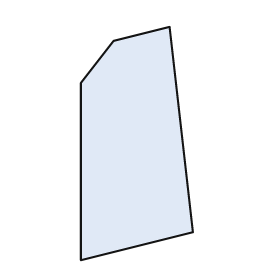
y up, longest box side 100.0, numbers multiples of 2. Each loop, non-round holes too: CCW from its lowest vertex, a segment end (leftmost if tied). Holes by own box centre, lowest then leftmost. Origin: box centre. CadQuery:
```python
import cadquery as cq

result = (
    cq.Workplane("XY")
    .moveTo(-24.0, -50.0)
    .lineTo(24.0, -38.0)
    .lineTo(14.0, 50.0)
    .lineTo(-10.0, 44.0)
    .lineTo(-24.0, 26.0)
    .close()
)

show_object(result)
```